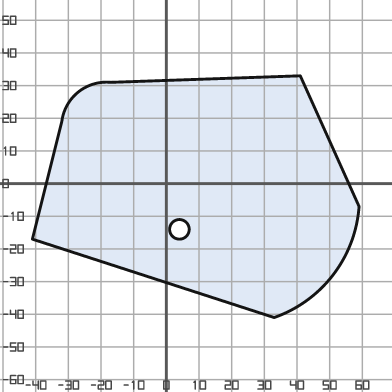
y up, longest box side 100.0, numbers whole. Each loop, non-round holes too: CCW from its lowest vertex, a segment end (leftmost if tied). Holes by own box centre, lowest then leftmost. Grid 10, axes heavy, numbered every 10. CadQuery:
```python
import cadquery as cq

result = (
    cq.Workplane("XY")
    .moveTo(33.0, -41.0)
    .threePointArc((51.0, -28.0), (59.0, -7.0))
    .lineTo(41.0, 33.0)
    .lineTo(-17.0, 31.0)
    .threePointArc((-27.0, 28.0), (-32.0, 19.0))
    .lineTo(-41.0, -17.0)
    .close()
    .moveTo(4.0, -14.0)
    .circle(3.0)
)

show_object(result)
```